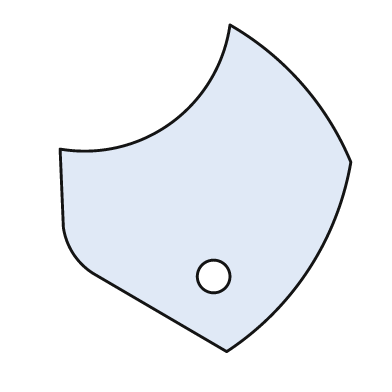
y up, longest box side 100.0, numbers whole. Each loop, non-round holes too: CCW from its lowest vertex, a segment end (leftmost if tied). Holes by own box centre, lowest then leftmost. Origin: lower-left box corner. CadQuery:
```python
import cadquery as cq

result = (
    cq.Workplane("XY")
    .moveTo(51.0, 0.0)
    .threePointArc((76.0, 25.0), (89.0, 58.0))
    .threePointArc((74.0, 82.0), (52.0, 100.0))
    .threePointArc((34.0, 70.0), (0.0, 62.0))
    .lineTo(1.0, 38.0)
    .threePointArc((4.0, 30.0), (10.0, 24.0))
    .close()
    .moveTo(47.0, 23.0)
    .circle(5.0)
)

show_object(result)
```